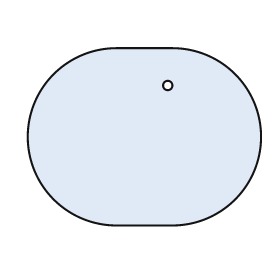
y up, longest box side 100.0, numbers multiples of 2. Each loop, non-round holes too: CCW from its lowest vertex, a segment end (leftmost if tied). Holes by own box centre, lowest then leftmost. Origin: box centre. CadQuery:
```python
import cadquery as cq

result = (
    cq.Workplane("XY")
    .moveTo(-12.0, -38.0)
    .lineTo(12.0, -38.0)
    .threePointArc((50.0, 0.0), (12.0, 38.0))
    .lineTo(-12.0, 38.0)
    .threePointArc((-50.0, 0.0), (-12.0, -38.0))
    .close()
    .moveTo(10.0, 22.0)
    .circle(2.0)
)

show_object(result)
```